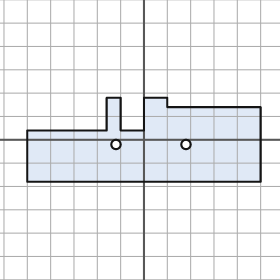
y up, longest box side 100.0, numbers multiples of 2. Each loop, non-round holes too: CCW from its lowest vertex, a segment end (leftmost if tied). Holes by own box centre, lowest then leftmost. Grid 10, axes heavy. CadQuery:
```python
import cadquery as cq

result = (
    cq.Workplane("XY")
    .moveTo(-50.0, -18.0)
    .lineTo(50.0, -18.0)
    .lineTo(50.0, 14.0)
    .lineTo(10.0, 14.0)
    .lineTo(10.0, 18.0)
    .lineTo(0.0, 18.0)
    .lineTo(0.0, 4.0)
    .lineTo(-10.0, 4.0)
    .lineTo(-10.0, 18.0)
    .lineTo(-16.0, 18.0)
    .lineTo(-16.0, 4.0)
    .lineTo(-50.0, 4.0)
    .close()
    .moveTo(-12.0, -2.0)
    .circle(2.0)
    .moveTo(18.0, -2.0)
    .circle(2.0)
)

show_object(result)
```